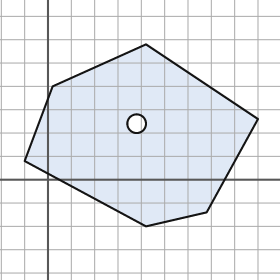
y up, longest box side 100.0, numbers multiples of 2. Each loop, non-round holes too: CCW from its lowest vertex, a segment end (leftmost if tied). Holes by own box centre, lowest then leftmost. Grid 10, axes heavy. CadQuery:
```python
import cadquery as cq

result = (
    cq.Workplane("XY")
    .moveTo(42.0, -20.0)
    .lineTo(68.0, -14.0)
    .lineTo(90.0, 26.0)
    .lineTo(42.0, 58.0)
    .lineTo(2.0, 40.0)
    .lineTo(-10.0, 8.0)
    .close()
    .moveTo(38.0, 24.0)
    .circle(4.0)
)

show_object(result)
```